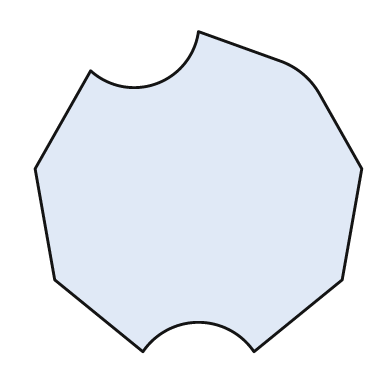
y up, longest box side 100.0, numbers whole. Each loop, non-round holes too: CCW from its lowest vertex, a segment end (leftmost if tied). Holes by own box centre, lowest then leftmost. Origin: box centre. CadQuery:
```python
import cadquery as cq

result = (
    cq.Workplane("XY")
    .moveTo(-17.0, -49.0)
    .threePointArc((0.0, -40.0), (17.0, -49.0))
    .lineTo(44.0, -27.0)
    .lineTo(50.0, 7.0)
    .lineTo(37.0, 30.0)
    .threePointArc((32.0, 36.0), (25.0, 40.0))
    .lineTo(0.0, 49.0)
    .threePointArc((-13.0, 33.0), (-33.0, 37.0))
    .lineTo(-50.0, 7.0)
    .lineTo(-44.0, -27.0)
    .close()
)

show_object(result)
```